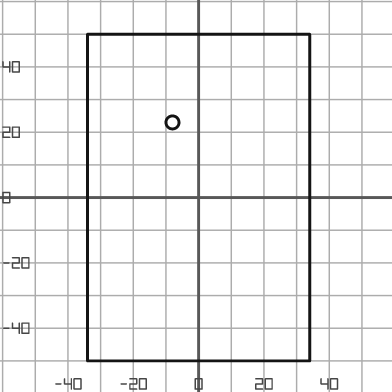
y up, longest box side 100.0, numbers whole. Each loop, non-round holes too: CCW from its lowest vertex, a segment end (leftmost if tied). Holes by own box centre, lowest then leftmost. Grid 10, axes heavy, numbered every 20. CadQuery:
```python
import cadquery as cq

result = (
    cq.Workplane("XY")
    .moveTo(-34.0, -50.0)
    .lineTo(34.0, -50.0)
    .lineTo(34.0, 50.0)
    .lineTo(-34.0, 50.0)
    .close()
    .moveTo(-8.0, 23.0)
    .circle(2.0)
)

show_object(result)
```